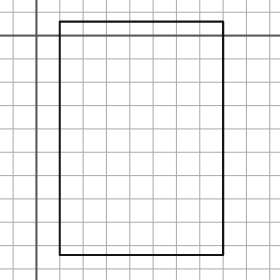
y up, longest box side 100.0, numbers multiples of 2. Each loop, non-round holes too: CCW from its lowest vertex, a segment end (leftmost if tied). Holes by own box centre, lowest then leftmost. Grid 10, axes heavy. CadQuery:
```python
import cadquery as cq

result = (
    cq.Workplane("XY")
    .moveTo(10.0, -94.0)
    .lineTo(80.0, -94.0)
    .lineTo(80.0, 6.0)
    .lineTo(10.0, 6.0)
    .close()
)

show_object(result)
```